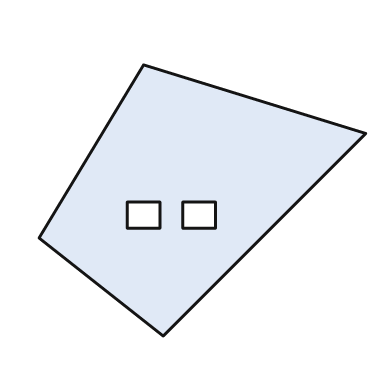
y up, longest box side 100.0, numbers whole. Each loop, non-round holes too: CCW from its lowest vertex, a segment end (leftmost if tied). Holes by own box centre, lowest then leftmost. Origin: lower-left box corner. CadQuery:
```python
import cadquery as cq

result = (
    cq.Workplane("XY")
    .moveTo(38.0, 0.0)
    .lineTo(100.0, 62.0)
    .lineTo(32.0, 83.0)
    .lineTo(0.0, 30.0)
    .close()
    .moveTo(27.0, 33.0)
    .lineTo(37.0, 33.0)
    .lineTo(37.0, 41.0)
    .lineTo(27.0, 41.0)
    .close()
    .moveTo(44.0, 33.0)
    .lineTo(54.0, 33.0)
    .lineTo(54.0, 41.0)
    .lineTo(44.0, 41.0)
    .close()
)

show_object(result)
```